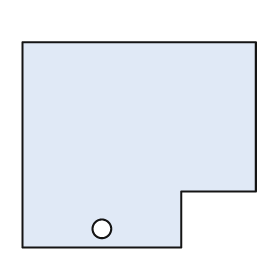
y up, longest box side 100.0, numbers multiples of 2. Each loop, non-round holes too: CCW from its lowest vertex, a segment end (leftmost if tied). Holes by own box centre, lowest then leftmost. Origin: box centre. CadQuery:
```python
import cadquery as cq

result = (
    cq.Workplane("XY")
    .moveTo(-50.0, -44.0)
    .lineTo(18.0, -44.0)
    .lineTo(18.0, -20.0)
    .lineTo(50.0, -20.0)
    .lineTo(50.0, 44.0)
    .lineTo(-50.0, 44.0)
    .close()
    .moveTo(-16.0, -36.0)
    .circle(4.0)
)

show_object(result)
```